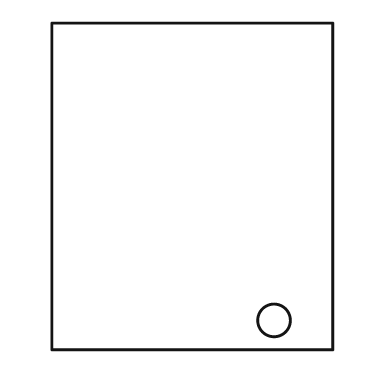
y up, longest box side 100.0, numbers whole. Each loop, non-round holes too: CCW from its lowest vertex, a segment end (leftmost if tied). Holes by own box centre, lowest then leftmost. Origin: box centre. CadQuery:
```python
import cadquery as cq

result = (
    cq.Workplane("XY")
    .moveTo(-43.0, -50.0)
    .lineTo(43.0, -50.0)
    .lineTo(43.0, 50.0)
    .lineTo(-43.0, 50.0)
    .close()
    .moveTo(25.0, -41.0)
    .circle(5.0)
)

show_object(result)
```